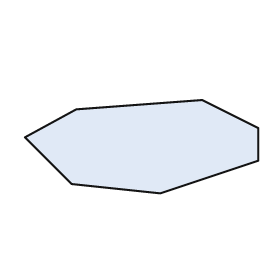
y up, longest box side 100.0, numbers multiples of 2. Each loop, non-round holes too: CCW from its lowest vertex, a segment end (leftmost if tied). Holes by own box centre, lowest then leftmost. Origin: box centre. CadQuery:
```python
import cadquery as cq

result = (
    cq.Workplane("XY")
    .moveTo(8.0, -20.0)
    .lineTo(50.0, -6.0)
    .lineTo(50.0, 8.0)
    .lineTo(26.0, 20.0)
    .lineTo(-28.0, 16.0)
    .lineTo(-50.0, 4.0)
    .lineTo(-30.0, -16.0)
    .close()
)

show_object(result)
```